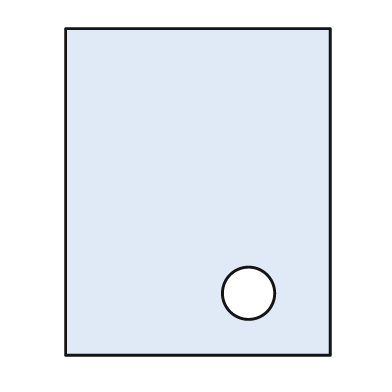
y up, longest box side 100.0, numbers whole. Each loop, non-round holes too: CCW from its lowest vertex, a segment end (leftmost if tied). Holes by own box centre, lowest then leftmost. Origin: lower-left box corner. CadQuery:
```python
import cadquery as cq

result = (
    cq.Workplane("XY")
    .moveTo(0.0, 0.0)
    .lineTo(81.0, 0.0)
    .lineTo(81.0, 100.0)
    .lineTo(0.0, 100.0)
    .close()
    .moveTo(56.0, 19.0)
    .circle(8.0)
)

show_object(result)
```